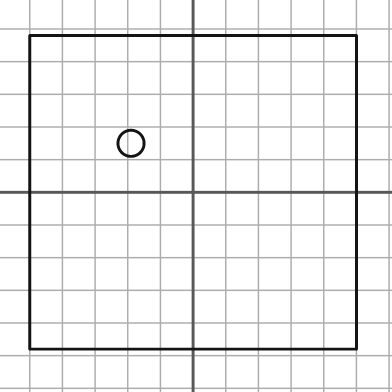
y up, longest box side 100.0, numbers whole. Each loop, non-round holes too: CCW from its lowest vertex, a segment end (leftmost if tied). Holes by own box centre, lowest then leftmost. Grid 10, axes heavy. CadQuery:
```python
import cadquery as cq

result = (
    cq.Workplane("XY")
    .moveTo(-50.0, -48.0)
    .lineTo(50.0, -48.0)
    .lineTo(50.0, 48.0)
    .lineTo(-50.0, 48.0)
    .close()
    .moveTo(-19.0, 15.0)
    .circle(4.0)
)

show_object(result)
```